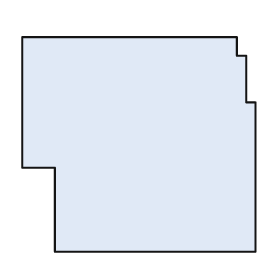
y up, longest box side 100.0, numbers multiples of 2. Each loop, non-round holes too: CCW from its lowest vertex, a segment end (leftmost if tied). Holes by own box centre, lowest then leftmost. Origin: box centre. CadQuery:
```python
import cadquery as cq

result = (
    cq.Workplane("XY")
    .moveTo(-36.0, -46.0)
    .lineTo(50.0, -46.0)
    .lineTo(50.0, 18.0)
    .lineTo(46.0, 18.0)
    .lineTo(46.0, 38.0)
    .lineTo(42.0, 38.0)
    .lineTo(42.0, 46.0)
    .lineTo(-50.0, 46.0)
    .lineTo(-50.0, -10.0)
    .lineTo(-36.0, -10.0)
    .close()
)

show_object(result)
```